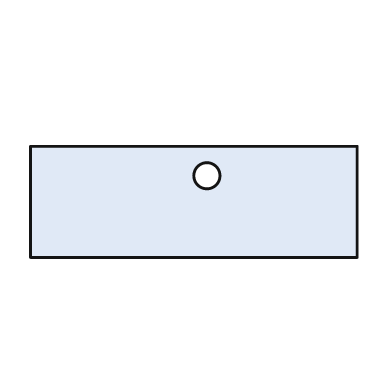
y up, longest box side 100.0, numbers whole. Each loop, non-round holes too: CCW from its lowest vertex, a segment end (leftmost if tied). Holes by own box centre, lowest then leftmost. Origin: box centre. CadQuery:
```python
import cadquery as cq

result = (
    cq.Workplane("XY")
    .moveTo(-50.0, -17.0)
    .lineTo(50.0, -17.0)
    .lineTo(50.0, 17.0)
    .lineTo(-50.0, 17.0)
    .close()
    .moveTo(4.0, 8.0)
    .circle(4.0)
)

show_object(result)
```